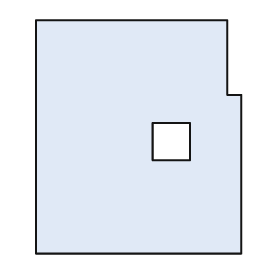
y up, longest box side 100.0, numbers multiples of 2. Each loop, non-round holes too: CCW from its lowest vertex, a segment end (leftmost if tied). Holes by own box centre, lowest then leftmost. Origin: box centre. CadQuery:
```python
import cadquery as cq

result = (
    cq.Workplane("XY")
    .moveTo(-44.0, -50.0)
    .lineTo(44.0, -50.0)
    .lineTo(44.0, 18.0)
    .lineTo(38.0, 18.0)
    .lineTo(38.0, 50.0)
    .lineTo(-44.0, 50.0)
    .close()
    .moveTo(6.0, -10.0)
    .lineTo(22.0, -10.0)
    .lineTo(22.0, 6.0)
    .lineTo(6.0, 6.0)
    .close()
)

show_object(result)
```